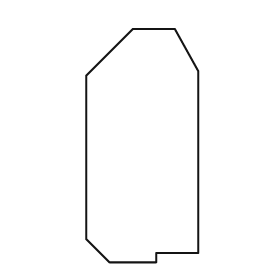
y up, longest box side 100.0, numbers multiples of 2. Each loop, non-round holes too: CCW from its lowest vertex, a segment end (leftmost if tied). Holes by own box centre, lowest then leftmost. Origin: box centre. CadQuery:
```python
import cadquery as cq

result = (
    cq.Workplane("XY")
    .moveTo(-14.0, -50.0)
    .lineTo(6.0, -50.0)
    .lineTo(6.0, -46.0)
    .lineTo(24.0, -46.0)
    .lineTo(24.0, 32.0)
    .lineTo(14.0, 50.0)
    .lineTo(-4.0, 50.0)
    .lineTo(-24.0, 30.0)
    .lineTo(-24.0, -40.0)
    .close()
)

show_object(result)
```